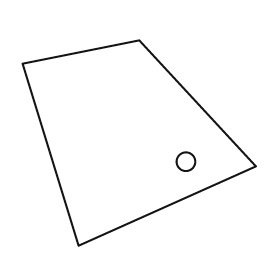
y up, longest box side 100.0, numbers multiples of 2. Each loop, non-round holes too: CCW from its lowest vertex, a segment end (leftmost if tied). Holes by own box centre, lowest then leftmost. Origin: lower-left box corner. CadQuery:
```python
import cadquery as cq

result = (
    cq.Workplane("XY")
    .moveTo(24.0, 0.0)
    .lineTo(100.0, 34.0)
    .lineTo(50.0, 88.0)
    .lineTo(0.0, 78.0)
    .close()
    .moveTo(70.0, 36.0)
    .circle(4.0)
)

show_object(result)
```